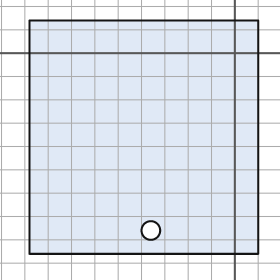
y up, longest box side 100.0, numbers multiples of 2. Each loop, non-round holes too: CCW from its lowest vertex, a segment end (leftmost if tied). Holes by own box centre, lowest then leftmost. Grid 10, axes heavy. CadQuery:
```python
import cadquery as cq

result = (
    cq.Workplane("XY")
    .moveTo(-88.0, -86.0)
    .lineTo(10.0, -86.0)
    .lineTo(10.0, 14.0)
    .lineTo(-88.0, 14.0)
    .close()
    .moveTo(-36.0, -76.0)
    .circle(4.0)
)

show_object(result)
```